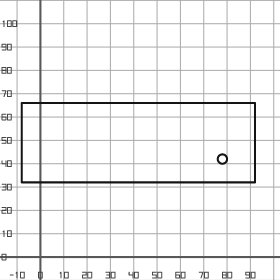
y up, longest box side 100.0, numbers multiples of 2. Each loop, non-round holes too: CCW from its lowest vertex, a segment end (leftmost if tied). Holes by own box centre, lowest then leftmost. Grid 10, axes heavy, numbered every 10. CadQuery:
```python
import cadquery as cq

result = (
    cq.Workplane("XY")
    .moveTo(-8.0, 32.0)
    .lineTo(92.0, 32.0)
    .lineTo(92.0, 66.0)
    .lineTo(-8.0, 66.0)
    .close()
    .moveTo(78.0, 42.0)
    .circle(2.0)
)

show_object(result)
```